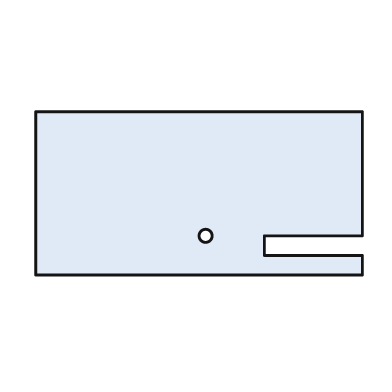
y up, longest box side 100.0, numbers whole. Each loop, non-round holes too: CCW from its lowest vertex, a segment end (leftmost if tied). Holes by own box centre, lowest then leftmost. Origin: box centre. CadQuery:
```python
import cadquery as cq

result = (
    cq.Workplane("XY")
    .moveTo(-50.0, -25.0)
    .lineTo(50.0, -25.0)
    .lineTo(50.0, -19.0)
    .lineTo(20.0, -19.0)
    .lineTo(20.0, -13.0)
    .lineTo(50.0, -13.0)
    .lineTo(50.0, 25.0)
    .lineTo(-50.0, 25.0)
    .close()
    .moveTo(2.0, -13.0)
    .circle(2.0)
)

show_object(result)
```